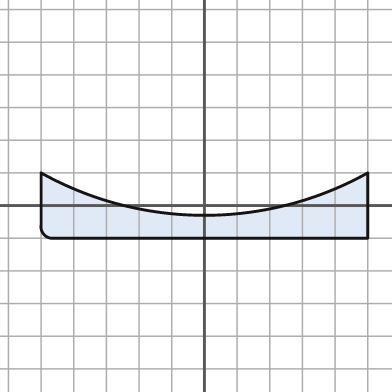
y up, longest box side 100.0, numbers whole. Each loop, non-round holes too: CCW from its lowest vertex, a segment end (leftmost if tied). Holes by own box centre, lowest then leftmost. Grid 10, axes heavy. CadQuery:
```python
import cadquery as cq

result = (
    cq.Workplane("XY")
    .moveTo(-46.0, -10.0)
    .lineTo(50.0, -10.0)
    .lineTo(50.0, 10.0)
    .threePointArc((0.0, -3.0), (-50.0, 10.0))
    .lineTo(-50.0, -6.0)
    .threePointArc((-49.0, -9.0), (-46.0, -10.0))
    .close()
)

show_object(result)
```